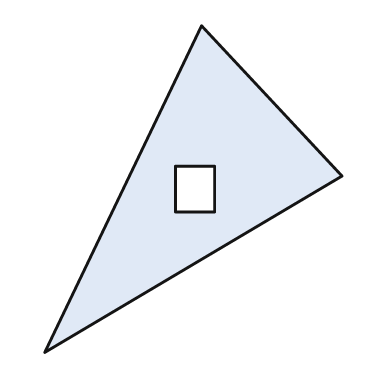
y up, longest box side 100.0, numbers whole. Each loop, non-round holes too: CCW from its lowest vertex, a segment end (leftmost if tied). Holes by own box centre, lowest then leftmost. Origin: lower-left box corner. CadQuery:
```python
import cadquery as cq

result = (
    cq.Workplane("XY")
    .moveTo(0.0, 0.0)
    .lineTo(91.0, 54.0)
    .lineTo(48.0, 100.0)
    .close()
    .moveTo(40.0, 43.0)
    .lineTo(52.0, 43.0)
    .lineTo(52.0, 57.0)
    .lineTo(40.0, 57.0)
    .close()
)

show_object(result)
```